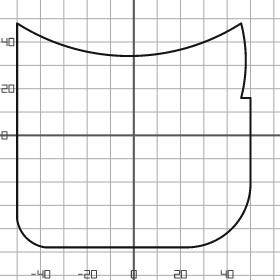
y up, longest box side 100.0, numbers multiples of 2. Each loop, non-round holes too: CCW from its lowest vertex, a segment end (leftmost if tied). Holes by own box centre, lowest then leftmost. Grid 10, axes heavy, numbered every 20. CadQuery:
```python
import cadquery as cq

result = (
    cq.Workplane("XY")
    .moveTo(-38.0, -48.0)
    .lineTo(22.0, -48.0)
    .threePointArc((42.0, -40.0), (50.0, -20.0))
    .lineTo(50.0, 16.0)
    .lineTo(46.0, 16.0)
    .threePointArc((48.0, 32.0), (46.0, 48.0))
    .threePointArc((-2.0, 34.0), (-50.0, 48.0))
    .lineTo(-50.0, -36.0)
    .threePointArc((-46.0, -44.0), (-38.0, -48.0))
    .close()
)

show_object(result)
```